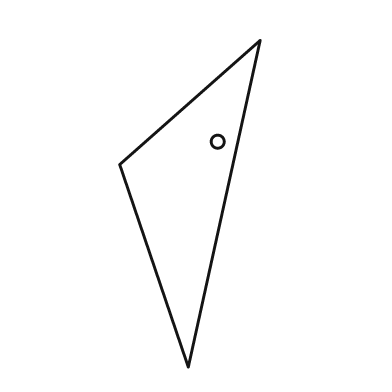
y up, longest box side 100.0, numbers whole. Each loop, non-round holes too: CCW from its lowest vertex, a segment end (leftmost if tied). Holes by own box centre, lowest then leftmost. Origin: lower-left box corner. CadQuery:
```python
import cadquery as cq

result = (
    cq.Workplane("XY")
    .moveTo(21.0, 0.0)
    .lineTo(43.0, 100.0)
    .lineTo(0.0, 62.0)
    .close()
    .moveTo(30.0, 69.0)
    .circle(2.0)
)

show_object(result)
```